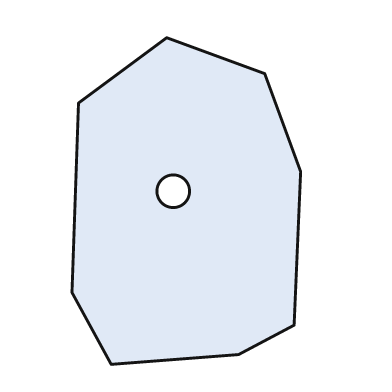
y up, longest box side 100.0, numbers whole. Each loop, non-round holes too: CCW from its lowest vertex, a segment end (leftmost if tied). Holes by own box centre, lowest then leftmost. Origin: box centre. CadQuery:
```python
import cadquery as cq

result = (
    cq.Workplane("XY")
    .moveTo(-23.0, -50.0)
    .lineTo(16.0, -47.0)
    .lineTo(33.0, -38.0)
    .lineTo(35.0, 9.0)
    .lineTo(24.0, 39.0)
    .lineTo(-6.0, 50.0)
    .lineTo(-33.0, 30.0)
    .lineTo(-35.0, -28.0)
    .close()
    .moveTo(-4.0, 3.0)
    .circle(5.0)
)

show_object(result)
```